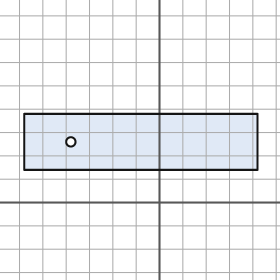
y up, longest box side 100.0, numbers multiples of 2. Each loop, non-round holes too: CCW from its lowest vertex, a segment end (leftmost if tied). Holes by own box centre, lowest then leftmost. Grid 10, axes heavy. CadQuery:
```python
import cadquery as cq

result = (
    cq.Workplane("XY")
    .moveTo(-58.0, 14.0)
    .lineTo(42.0, 14.0)
    .lineTo(42.0, 38.0)
    .lineTo(-58.0, 38.0)
    .close()
    .moveTo(-38.0, 26.0)
    .circle(2.0)
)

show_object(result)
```